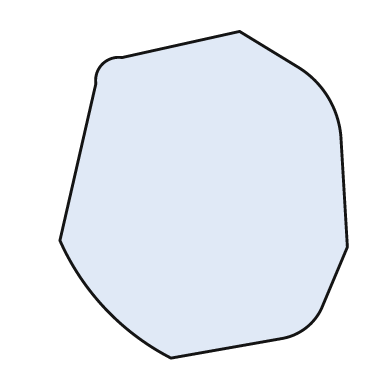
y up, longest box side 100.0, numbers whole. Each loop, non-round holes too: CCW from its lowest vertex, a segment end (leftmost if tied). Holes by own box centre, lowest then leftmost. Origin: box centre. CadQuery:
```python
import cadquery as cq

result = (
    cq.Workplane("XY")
    .moveTo(-10.0, -50.0)
    .lineTo(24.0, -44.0)
    .threePointArc((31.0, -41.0), (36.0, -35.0))
    .lineTo(44.0, -16.0)
    .lineTo(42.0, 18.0)
    .threePointArc((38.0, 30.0), (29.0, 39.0))
    .lineTo(11.0, 50.0)
    .lineTo(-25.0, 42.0)
    .threePointArc((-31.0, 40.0), (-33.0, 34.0))
    .lineTo(-44.0, -14.0)
    .threePointArc((-30.0, -35.0), (-10.0, -50.0))
    .close()
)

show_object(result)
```